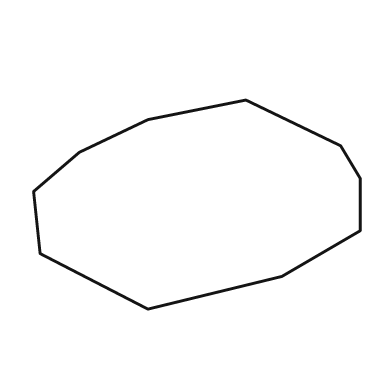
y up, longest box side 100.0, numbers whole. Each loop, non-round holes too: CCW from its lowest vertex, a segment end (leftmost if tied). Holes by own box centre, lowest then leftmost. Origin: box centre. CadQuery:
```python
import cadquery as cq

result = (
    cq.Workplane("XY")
    .moveTo(-15.0, -32.0)
    .lineTo(26.0, -22.0)
    .lineTo(50.0, -8.0)
    .lineTo(50.0, 8.0)
    .lineTo(44.0, 18.0)
    .lineTo(15.0, 32.0)
    .lineTo(-15.0, 26.0)
    .lineTo(-36.0, 16.0)
    .lineTo(-50.0, 4.0)
    .lineTo(-48.0, -15.0)
    .close()
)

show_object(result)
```